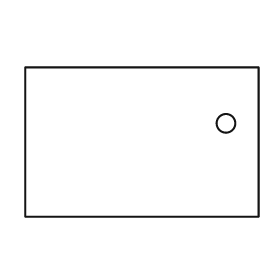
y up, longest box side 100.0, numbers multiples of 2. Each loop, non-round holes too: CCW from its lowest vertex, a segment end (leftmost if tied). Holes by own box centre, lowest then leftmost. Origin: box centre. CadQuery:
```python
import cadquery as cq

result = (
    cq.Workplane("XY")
    .moveTo(-50.0, -32.0)
    .lineTo(50.0, -32.0)
    .lineTo(50.0, 32.0)
    .lineTo(-50.0, 32.0)
    .close()
    .moveTo(36.0, 8.0)
    .circle(4.0)
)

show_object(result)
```